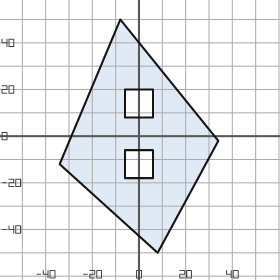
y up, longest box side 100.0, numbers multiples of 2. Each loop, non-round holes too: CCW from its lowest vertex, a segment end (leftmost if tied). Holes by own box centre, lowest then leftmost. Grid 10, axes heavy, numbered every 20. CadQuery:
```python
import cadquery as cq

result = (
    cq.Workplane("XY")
    .moveTo(8.0, -50.0)
    .lineTo(34.0, -2.0)
    .lineTo(-8.0, 50.0)
    .lineTo(-34.0, -12.0)
    .close()
    .moveTo(-6.0, -18.0)
    .lineTo(6.0, -18.0)
    .lineTo(6.0, -6.0)
    .lineTo(-6.0, -6.0)
    .close()
    .moveTo(-6.0, 8.0)
    .lineTo(6.0, 8.0)
    .lineTo(6.0, 20.0)
    .lineTo(-6.0, 20.0)
    .close()
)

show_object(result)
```